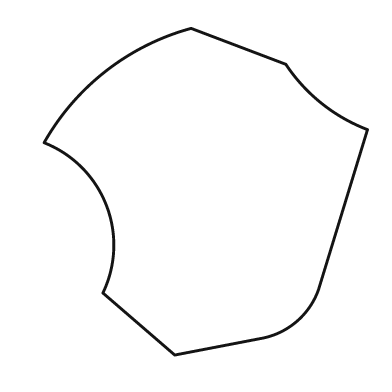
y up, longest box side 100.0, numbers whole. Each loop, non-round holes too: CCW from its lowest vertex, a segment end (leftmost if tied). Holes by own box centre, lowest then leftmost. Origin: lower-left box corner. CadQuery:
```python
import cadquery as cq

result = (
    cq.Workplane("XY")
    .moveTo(40.0, 0.0)
    .lineTo(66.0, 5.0)
    .threePointArc((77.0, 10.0), (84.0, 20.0))
    .lineTo(99.0, 69.0)
    .threePointArc((85.0, 77.0), (74.0, 89.0))
    .lineTo(45.0, 100.0)
    .threePointArc((19.0, 87.0), (0.0, 65.0))
    .threePointArc((19.0, 46.0), (18.0, 19.0))
    .close()
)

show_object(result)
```